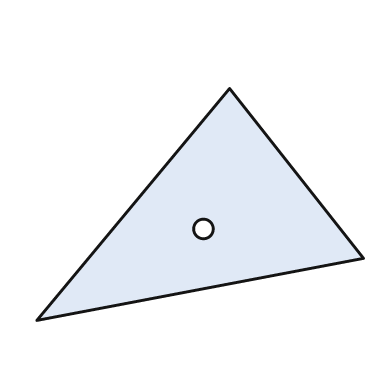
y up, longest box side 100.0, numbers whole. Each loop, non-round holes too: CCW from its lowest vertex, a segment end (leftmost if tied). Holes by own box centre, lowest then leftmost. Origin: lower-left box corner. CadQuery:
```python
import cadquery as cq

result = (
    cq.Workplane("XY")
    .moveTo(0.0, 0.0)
    .lineTo(100.0, 19.0)
    .lineTo(59.0, 71.0)
    .close()
    .moveTo(51.0, 28.0)
    .circle(3.0)
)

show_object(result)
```